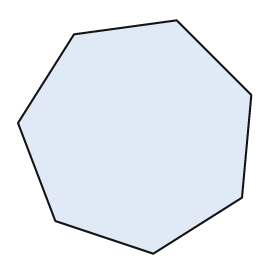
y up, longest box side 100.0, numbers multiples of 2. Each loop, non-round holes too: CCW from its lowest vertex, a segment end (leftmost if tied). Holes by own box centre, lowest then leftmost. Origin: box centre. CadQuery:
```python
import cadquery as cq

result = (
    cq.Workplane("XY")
    .moveTo(8.0, -50.0)
    .lineTo(46.0, -26.0)
    .lineTo(50.0, 18.0)
    .lineTo(18.0, 50.0)
    .lineTo(-26.0, 44.0)
    .lineTo(-50.0, 6.0)
    .lineTo(-34.0, -36.0)
    .close()
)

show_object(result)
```